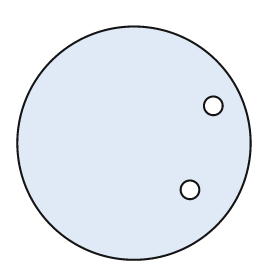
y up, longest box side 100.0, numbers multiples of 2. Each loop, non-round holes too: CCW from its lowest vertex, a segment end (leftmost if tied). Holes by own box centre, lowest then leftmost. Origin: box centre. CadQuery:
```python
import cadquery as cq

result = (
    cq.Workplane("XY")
    .moveTo(0.0, 0.0)
    .circle(50.0)
    .moveTo(24.0, -20.0)
    .circle(4.0)
    .moveTo(34.0, 16.0)
    .circle(4.0)
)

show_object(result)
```